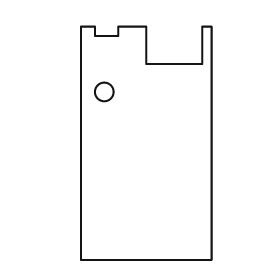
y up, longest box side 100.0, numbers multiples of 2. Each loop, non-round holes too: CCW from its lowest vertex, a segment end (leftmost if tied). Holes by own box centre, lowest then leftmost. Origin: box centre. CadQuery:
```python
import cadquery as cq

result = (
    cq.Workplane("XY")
    .moveTo(-28.0, -50.0)
    .lineTo(28.0, -50.0)
    .lineTo(28.0, 50.0)
    .lineTo(24.0, 50.0)
    .lineTo(24.0, 34.0)
    .lineTo(0.0, 34.0)
    .lineTo(0.0, 50.0)
    .lineTo(-12.0, 50.0)
    .lineTo(-12.0, 46.0)
    .lineTo(-22.0, 46.0)
    .lineTo(-22.0, 50.0)
    .lineTo(-28.0, 50.0)
    .close()
    .moveTo(-18.0, 22.0)
    .circle(4.0)
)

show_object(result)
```